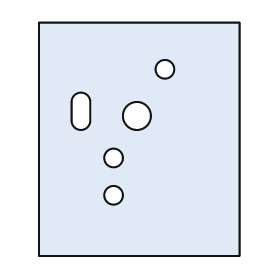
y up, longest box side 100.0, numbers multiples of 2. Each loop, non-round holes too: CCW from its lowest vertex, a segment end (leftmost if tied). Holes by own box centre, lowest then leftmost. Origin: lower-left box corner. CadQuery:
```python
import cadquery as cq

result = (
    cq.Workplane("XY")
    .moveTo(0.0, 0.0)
    .lineTo(86.0, 0.0)
    .lineTo(86.0, 100.0)
    .lineTo(0.0, 100.0)
    .close()
    .moveTo(32.0, 26.0)
    .circle(4.0)
    .moveTo(32.0, 42.0)
    .circle(4.0)
    .moveTo(42.0, 60.0)
    .circle(6.0)
    .moveTo(14.0, 58.0)
    .threePointArc((18.0, 54.0), (22.0, 58.0))
    .lineTo(22.0, 66.0)
    .threePointArc((18.0, 70.0), (14.0, 66.0))
    .close()
    .moveTo(54.0, 80.0)
    .circle(4.0)
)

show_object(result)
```